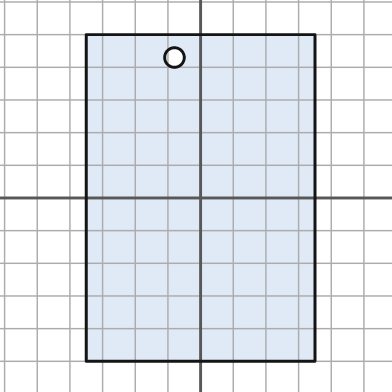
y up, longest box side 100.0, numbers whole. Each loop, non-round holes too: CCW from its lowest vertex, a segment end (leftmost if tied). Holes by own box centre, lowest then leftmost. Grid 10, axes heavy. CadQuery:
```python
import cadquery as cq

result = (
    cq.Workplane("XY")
    .moveTo(-35.0, -50.0)
    .lineTo(35.0, -50.0)
    .lineTo(35.0, 50.0)
    .lineTo(-35.0, 50.0)
    .close()
    .moveTo(-8.0, 43.0)
    .circle(3.0)
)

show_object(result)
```